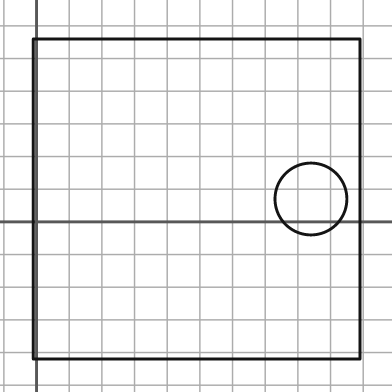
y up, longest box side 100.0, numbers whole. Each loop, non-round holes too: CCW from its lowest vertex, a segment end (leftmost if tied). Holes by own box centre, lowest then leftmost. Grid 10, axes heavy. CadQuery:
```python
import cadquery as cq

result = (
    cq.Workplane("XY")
    .moveTo(-1.0, -42.0)
    .lineTo(99.0, -42.0)
    .lineTo(99.0, 56.0)
    .lineTo(-1.0, 56.0)
    .close()
    .moveTo(84.0, 7.0)
    .circle(11.0)
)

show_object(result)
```